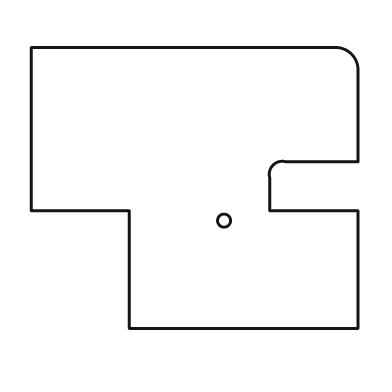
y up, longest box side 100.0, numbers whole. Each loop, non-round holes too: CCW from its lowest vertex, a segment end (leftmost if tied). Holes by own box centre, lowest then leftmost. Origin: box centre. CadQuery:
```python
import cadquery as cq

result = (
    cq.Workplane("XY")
    .moveTo(-20.0, -43.0)
    .lineTo(50.0, -43.0)
    .lineTo(50.0, -7.0)
    .lineTo(23.0, -7.0)
    .lineTo(23.0, 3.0)
    .threePointArc((24.0, 7.0), (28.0, 8.0))
    .lineTo(50.0, 8.0)
    .lineTo(50.0, 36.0)
    .threePointArc((48.0, 41.0), (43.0, 43.0))
    .lineTo(-50.0, 43.0)
    .lineTo(-50.0, -7.0)
    .lineTo(-20.0, -7.0)
    .close()
    .moveTo(9.0, -10.0)
    .circle(2.0)
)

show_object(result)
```